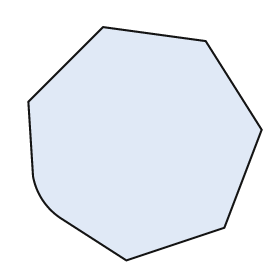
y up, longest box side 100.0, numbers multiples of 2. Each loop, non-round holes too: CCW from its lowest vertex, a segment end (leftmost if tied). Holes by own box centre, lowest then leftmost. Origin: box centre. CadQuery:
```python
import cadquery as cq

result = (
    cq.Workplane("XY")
    .moveTo(-8.0, -50.0)
    .lineTo(34.0, -36.0)
    .lineTo(50.0, 6.0)
    .lineTo(26.0, 44.0)
    .lineTo(-18.0, 50.0)
    .lineTo(-50.0, 18.0)
    .lineTo(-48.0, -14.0)
    .threePointArc((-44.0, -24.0), (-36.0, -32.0))
    .close()
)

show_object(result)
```